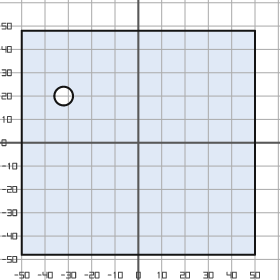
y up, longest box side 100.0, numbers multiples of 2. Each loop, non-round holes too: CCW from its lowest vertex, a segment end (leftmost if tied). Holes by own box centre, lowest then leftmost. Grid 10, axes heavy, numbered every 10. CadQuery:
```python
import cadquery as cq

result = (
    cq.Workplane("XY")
    .moveTo(-50.0, -48.0)
    .lineTo(50.0, -48.0)
    .lineTo(50.0, 48.0)
    .lineTo(-50.0, 48.0)
    .close()
    .moveTo(-32.0, 20.0)
    .circle(4.0)
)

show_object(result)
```